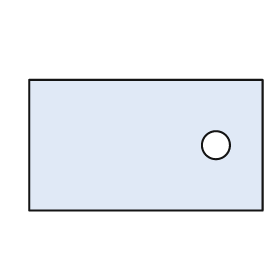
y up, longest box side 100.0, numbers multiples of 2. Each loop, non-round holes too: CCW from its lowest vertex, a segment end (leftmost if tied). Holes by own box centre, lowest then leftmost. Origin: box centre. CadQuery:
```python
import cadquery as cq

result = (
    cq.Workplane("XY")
    .moveTo(-50.0, -28.0)
    .lineTo(50.0, -28.0)
    .lineTo(50.0, 28.0)
    .lineTo(-50.0, 28.0)
    .close()
    .moveTo(30.0, 0.0)
    .circle(6.0)
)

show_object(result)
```